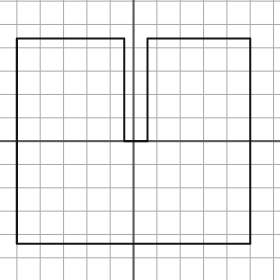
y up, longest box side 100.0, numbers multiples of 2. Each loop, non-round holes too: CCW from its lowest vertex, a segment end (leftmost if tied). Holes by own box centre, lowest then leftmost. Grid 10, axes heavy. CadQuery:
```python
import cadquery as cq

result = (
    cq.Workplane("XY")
    .moveTo(-50.0, -44.0)
    .lineTo(50.0, -44.0)
    .lineTo(50.0, 44.0)
    .lineTo(6.0, 44.0)
    .lineTo(6.0, 0.0)
    .lineTo(-4.0, 0.0)
    .lineTo(-4.0, 44.0)
    .lineTo(-50.0, 44.0)
    .close()
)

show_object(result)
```